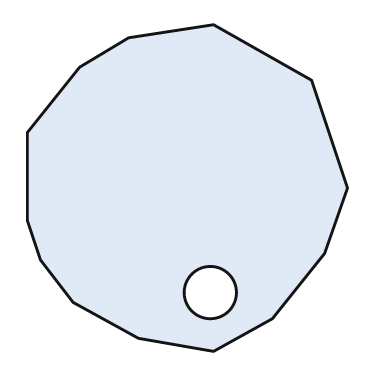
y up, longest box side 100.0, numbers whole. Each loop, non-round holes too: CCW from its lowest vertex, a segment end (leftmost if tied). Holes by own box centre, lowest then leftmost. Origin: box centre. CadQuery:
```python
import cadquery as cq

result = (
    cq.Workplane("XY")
    .moveTo(8.0, -50.0)
    .lineTo(26.0, -40.0)
    .lineTo(42.0, -20.0)
    .lineTo(49.0, 0.0)
    .lineTo(38.0, 33.0)
    .lineTo(8.0, 50.0)
    .lineTo(-18.0, 46.0)
    .lineTo(-33.0, 37.0)
    .lineTo(-49.0, 17.0)
    .lineTo(-49.0, -10.0)
    .lineTo(-45.0, -22.0)
    .lineTo(-35.0, -35.0)
    .lineTo(-15.0, -46.0)
    .close()
    .moveTo(7.0, -32.0)
    .circle(8.0)
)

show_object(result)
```